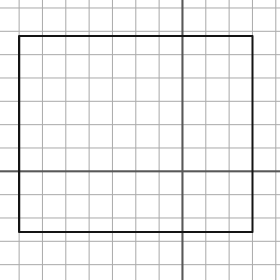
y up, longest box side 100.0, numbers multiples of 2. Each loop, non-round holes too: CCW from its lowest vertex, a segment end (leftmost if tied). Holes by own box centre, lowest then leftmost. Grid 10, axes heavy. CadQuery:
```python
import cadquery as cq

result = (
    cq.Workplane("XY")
    .moveTo(-70.0, -26.0)
    .lineTo(30.0, -26.0)
    .lineTo(30.0, 58.0)
    .lineTo(-70.0, 58.0)
    .close()
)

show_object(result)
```